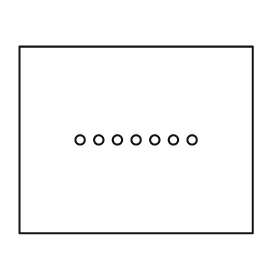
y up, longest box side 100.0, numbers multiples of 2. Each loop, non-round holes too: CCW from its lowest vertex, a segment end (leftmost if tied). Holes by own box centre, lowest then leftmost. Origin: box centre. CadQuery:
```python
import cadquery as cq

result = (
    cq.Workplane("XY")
    .moveTo(-50.0, -40.0)
    .lineTo(50.0, -40.0)
    .lineTo(50.0, 40.0)
    .lineTo(-50.0, 40.0)
    .close()
    .moveTo(-24.0, 0.0)
    .circle(2.0)
    .moveTo(-16.0, 0.0)
    .circle(2.0)
    .moveTo(-8.0, 0.0)
    .circle(2.0)
    .moveTo(0.0, 0.0)
    .circle(2.0)
    .moveTo(8.0, 0.0)
    .circle(2.0)
    .moveTo(16.0, 0.0)
    .circle(2.0)
    .moveTo(24.0, 0.0)
    .circle(2.0)
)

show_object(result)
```